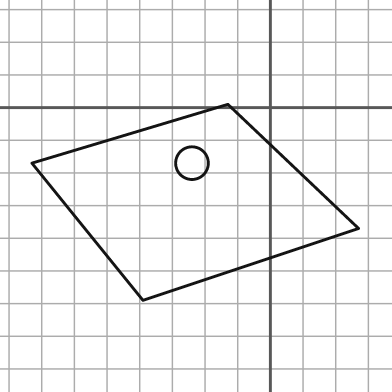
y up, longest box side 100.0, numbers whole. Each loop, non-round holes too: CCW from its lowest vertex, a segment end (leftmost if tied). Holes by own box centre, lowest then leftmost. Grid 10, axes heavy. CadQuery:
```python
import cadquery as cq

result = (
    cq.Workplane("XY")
    .moveTo(-39.0, -59.0)
    .lineTo(27.0, -37.0)
    .lineTo(-13.0, 1.0)
    .lineTo(-73.0, -17.0)
    .close()
    .moveTo(-24.0, -17.0)
    .circle(5.0)
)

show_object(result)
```